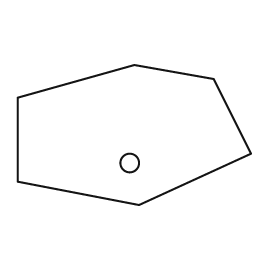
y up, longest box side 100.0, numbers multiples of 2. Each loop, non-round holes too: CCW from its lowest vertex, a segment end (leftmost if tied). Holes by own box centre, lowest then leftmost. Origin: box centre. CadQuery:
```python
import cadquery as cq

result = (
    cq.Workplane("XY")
    .moveTo(2.0, -30.0)
    .lineTo(50.0, -8.0)
    .lineTo(34.0, 24.0)
    .lineTo(0.0, 30.0)
    .lineTo(-50.0, 16.0)
    .lineTo(-50.0, -20.0)
    .close()
    .moveTo(-2.0, -12.0)
    .circle(4.0)
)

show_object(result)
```